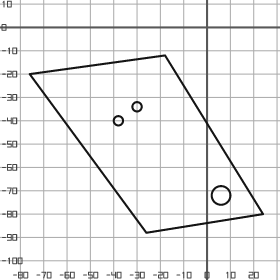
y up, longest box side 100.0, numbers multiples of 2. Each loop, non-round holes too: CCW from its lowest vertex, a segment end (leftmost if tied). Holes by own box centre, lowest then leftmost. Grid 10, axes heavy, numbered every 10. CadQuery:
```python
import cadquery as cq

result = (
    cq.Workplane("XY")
    .moveTo(-26.0, -88.0)
    .lineTo(24.0, -80.0)
    .lineTo(-18.0, -12.0)
    .lineTo(-76.0, -20.0)
    .close()
    .moveTo(6.0, -72.0)
    .circle(4.0)
    .moveTo(-38.0, -40.0)
    .circle(2.0)
    .moveTo(-30.0, -34.0)
    .circle(2.0)
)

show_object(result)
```